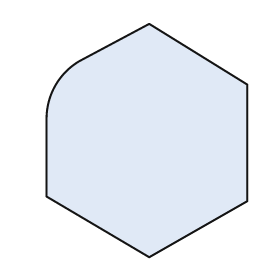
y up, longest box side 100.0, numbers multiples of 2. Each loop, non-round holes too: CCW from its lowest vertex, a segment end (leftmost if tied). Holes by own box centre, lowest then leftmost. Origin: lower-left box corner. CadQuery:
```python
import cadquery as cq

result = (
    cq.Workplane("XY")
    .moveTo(44.0, 0.0)
    .lineTo(86.0, 24.0)
    .lineTo(86.0, 74.0)
    .lineTo(44.0, 100.0)
    .lineTo(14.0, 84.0)
    .threePointArc((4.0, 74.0), (0.0, 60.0))
    .lineTo(0.0, 26.0)
    .close()
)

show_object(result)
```